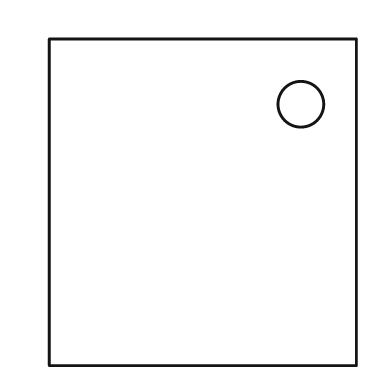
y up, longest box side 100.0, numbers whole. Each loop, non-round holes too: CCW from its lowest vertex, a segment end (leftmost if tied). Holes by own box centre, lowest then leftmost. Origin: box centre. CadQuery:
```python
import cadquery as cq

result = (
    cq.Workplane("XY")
    .moveTo(-47.0, -50.0)
    .lineTo(47.0, -50.0)
    .lineTo(47.0, 50.0)
    .lineTo(-47.0, 50.0)
    .close()
    .moveTo(30.0, 30.0)
    .circle(7.0)
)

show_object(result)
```